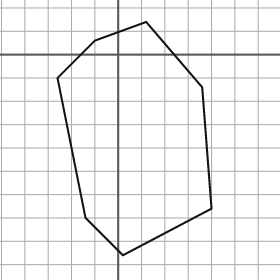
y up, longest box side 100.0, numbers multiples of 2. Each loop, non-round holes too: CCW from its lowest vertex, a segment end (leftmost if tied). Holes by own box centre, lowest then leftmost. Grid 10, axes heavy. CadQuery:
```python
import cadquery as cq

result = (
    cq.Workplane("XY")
    .moveTo(2.0, -86.0)
    .lineTo(40.0, -66.0)
    .lineTo(36.0, -14.0)
    .lineTo(12.0, 14.0)
    .lineTo(-10.0, 6.0)
    .lineTo(-26.0, -10.0)
    .lineTo(-14.0, -70.0)
    .close()
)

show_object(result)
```